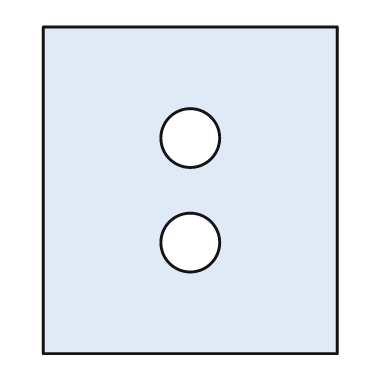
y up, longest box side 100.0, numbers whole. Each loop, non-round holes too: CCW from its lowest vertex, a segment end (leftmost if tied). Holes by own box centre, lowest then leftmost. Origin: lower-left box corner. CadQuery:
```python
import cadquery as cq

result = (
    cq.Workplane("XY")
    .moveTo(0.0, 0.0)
    .lineTo(90.0, 0.0)
    .lineTo(90.0, 100.0)
    .lineTo(0.0, 100.0)
    .close()
    .moveTo(45.0, 34.0)
    .circle(9.0)
    .moveTo(45.0, 66.0)
    .circle(9.0)
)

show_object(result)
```